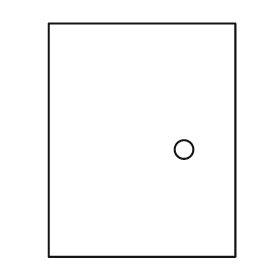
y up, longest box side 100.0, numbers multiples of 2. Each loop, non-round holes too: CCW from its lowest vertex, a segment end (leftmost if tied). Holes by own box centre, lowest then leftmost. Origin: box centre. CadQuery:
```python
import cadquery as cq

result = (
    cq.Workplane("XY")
    .moveTo(-40.0, -50.0)
    .lineTo(40.0, -50.0)
    .lineTo(40.0, 50.0)
    .lineTo(-40.0, 50.0)
    .close()
    .moveTo(18.0, -4.0)
    .circle(4.0)
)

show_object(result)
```